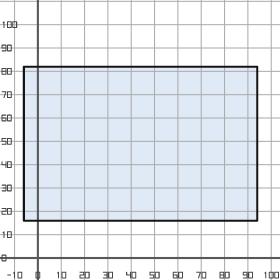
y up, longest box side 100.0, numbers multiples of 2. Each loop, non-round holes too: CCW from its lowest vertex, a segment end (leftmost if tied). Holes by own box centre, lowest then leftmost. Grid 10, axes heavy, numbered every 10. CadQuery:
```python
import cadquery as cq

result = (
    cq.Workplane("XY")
    .moveTo(-6.0, 16.0)
    .lineTo(94.0, 16.0)
    .lineTo(94.0, 82.0)
    .lineTo(-6.0, 82.0)
    .close()
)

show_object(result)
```